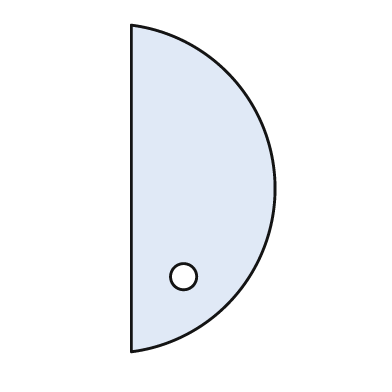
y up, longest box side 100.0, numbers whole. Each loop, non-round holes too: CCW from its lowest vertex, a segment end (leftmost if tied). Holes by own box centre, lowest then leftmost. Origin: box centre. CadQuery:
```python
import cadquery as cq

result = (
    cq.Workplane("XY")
    .moveTo(-22.0, -50.0)
    .threePointArc((22.0, 0.0), (-22.0, 50.0))
    .close()
    .moveTo(-6.0, -27.0)
    .circle(4.0)
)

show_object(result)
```